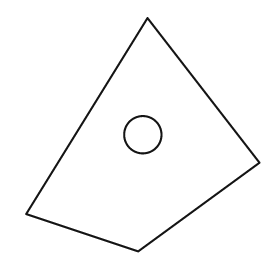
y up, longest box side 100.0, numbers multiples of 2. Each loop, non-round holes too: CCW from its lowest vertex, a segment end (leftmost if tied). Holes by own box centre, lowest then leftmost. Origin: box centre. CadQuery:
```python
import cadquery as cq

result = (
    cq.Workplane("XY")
    .moveTo(-2.0, -50.0)
    .lineTo(50.0, -12.0)
    .lineTo(2.0, 50.0)
    .lineTo(-50.0, -34.0)
    .close()
    .moveTo(0.0, 0.0)
    .circle(8.0)
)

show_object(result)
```